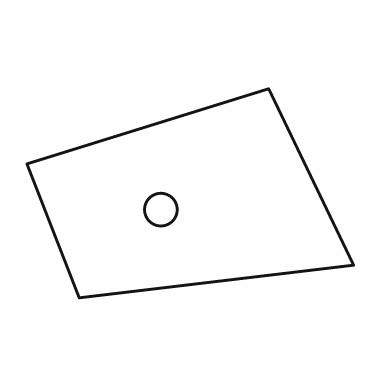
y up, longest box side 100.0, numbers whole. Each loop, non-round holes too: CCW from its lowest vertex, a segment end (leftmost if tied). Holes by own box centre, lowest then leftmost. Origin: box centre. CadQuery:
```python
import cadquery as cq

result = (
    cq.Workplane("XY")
    .moveTo(-34.0, -32.0)
    .lineTo(50.0, -22.0)
    .lineTo(24.0, 32.0)
    .lineTo(-50.0, 9.0)
    .close()
    .moveTo(-9.0, -5.0)
    .circle(5.0)
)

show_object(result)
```